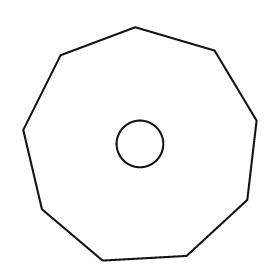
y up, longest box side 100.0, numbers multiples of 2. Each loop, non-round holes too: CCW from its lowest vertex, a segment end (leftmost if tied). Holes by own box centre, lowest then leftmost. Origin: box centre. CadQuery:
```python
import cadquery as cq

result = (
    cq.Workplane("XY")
    .moveTo(-16.0, -50.0)
    .lineTo(20.0, -48.0)
    .lineTo(46.0, -24.0)
    .lineTo(50.0, 10.0)
    .lineTo(32.0, 40.0)
    .lineTo(-2.0, 50.0)
    .lineTo(-34.0, 38.0)
    .lineTo(-50.0, 6.0)
    .lineTo(-42.0, -28.0)
    .close()
    .moveTo(0.0, 0.0)
    .circle(10.0)
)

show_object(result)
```